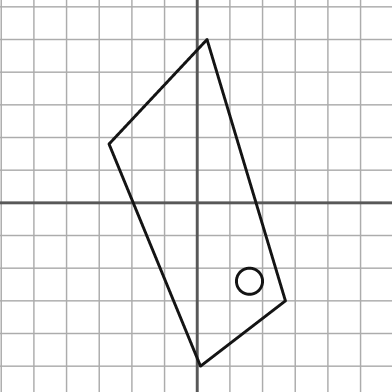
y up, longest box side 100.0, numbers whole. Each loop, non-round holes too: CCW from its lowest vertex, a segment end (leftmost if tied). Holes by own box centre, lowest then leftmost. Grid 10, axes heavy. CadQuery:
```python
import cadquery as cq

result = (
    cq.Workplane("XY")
    .moveTo(1.0, -50.0)
    .lineTo(27.0, -30.0)
    .lineTo(3.0, 50.0)
    .lineTo(-27.0, 18.0)
    .close()
    .moveTo(16.0, -24.0)
    .circle(4.0)
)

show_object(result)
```